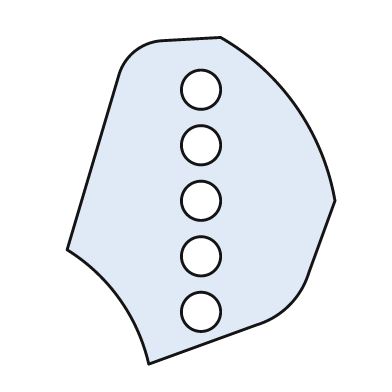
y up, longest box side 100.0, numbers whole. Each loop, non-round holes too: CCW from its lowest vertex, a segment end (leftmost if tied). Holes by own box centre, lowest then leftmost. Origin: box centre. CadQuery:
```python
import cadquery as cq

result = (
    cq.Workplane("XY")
    .moveTo(-16.0, -50.0)
    .lineTo(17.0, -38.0)
    .threePointArc((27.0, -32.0), (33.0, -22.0))
    .lineTo(41.0, 0.0)
    .threePointArc((29.0, 29.0), (6.0, 50.0))
    .lineTo(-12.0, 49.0)
    .threePointArc((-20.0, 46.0), (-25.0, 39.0))
    .lineTo(-41.0, -15.0)
    .threePointArc((-25.0, -30.0), (-16.0, -50.0))
    .close()
    .moveTo(0.0, -34.0)
    .circle(6.0)
    .moveTo(0.0, -17.0)
    .circle(6.0)
    .moveTo(0.0, 0.0)
    .circle(6.0)
    .moveTo(0.0, 17.0)
    .circle(6.0)
    .moveTo(0.0, 34.0)
    .circle(6.0)
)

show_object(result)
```